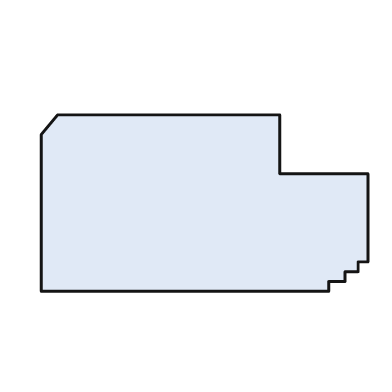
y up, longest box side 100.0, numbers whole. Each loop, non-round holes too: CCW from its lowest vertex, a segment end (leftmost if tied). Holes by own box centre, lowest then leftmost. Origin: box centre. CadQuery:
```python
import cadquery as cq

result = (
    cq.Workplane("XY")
    .moveTo(-50.0, -27.0)
    .lineTo(38.0, -27.0)
    .lineTo(38.0, -24.0)
    .lineTo(43.0, -24.0)
    .lineTo(43.0, -21.0)
    .lineTo(47.0, -21.0)
    .lineTo(47.0, -18.0)
    .lineTo(50.0, -18.0)
    .lineTo(50.0, 9.0)
    .lineTo(23.0, 9.0)
    .lineTo(23.0, 27.0)
    .lineTo(-45.0, 27.0)
    .lineTo(-50.0, 21.0)
    .close()
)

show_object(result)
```